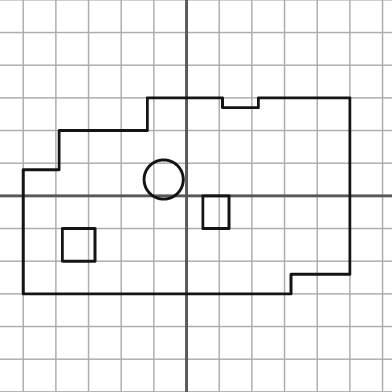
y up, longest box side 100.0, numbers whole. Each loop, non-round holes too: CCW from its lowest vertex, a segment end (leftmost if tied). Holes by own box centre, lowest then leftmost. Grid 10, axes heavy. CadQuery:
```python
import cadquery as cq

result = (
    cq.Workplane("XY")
    .moveTo(-50.0, -30.0)
    .lineTo(32.0, -30.0)
    .lineTo(32.0, -24.0)
    .lineTo(50.0, -24.0)
    .lineTo(50.0, 30.0)
    .lineTo(22.0, 30.0)
    .lineTo(22.0, 27.0)
    .lineTo(11.0, 27.0)
    .lineTo(11.0, 30.0)
    .lineTo(-12.0, 30.0)
    .lineTo(-12.0, 20.0)
    .lineTo(-39.0, 20.0)
    .lineTo(-39.0, 8.0)
    .lineTo(-50.0, 8.0)
    .close()
    .moveTo(-38.0, -20.0)
    .lineTo(-28.0, -20.0)
    .lineTo(-28.0, -10.0)
    .lineTo(-38.0, -10.0)
    .close()
    .moveTo(5.0, -10.0)
    .lineTo(13.0, -10.0)
    .lineTo(13.0, 0.0)
    .lineTo(5.0, 0.0)
    .close()
    .moveTo(-7.0, 5.0)
    .circle(6.0)
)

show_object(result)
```